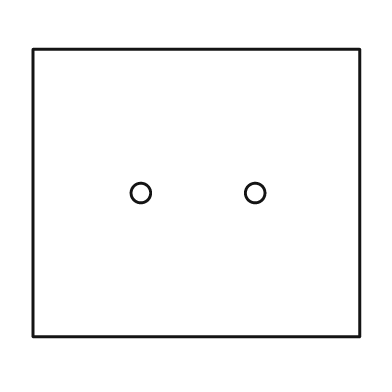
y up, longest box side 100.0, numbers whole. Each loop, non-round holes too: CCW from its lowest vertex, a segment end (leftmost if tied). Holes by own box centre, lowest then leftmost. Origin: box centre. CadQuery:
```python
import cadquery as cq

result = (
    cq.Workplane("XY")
    .moveTo(-50.0, -44.0)
    .lineTo(50.0, -44.0)
    .lineTo(50.0, 44.0)
    .lineTo(-50.0, 44.0)
    .close()
    .moveTo(-17.0, 0.0)
    .circle(3.0)
    .moveTo(18.0, 0.0)
    .circle(3.0)
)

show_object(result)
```